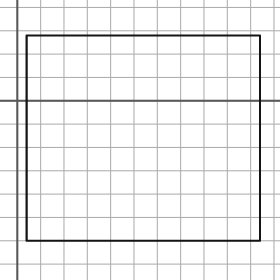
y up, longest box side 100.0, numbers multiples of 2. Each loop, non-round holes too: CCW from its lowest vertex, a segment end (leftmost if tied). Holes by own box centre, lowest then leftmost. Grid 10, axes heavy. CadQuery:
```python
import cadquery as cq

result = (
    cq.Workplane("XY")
    .moveTo(4.0, -60.0)
    .lineTo(104.0, -60.0)
    .lineTo(104.0, 28.0)
    .lineTo(4.0, 28.0)
    .close()
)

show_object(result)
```